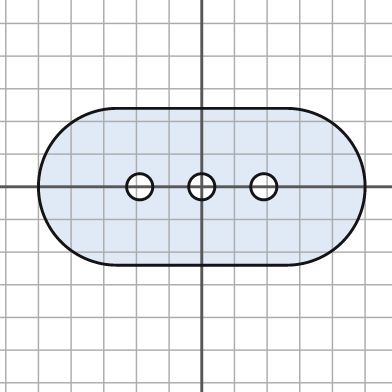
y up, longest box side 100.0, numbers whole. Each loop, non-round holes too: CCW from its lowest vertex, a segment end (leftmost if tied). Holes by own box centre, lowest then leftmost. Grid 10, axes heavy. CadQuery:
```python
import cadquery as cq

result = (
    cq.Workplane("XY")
    .moveTo(-26.0, -24.0)
    .lineTo(26.0, -24.0)
    .threePointArc((50.0, 0.0), (26.0, 24.0))
    .lineTo(-26.0, 24.0)
    .threePointArc((-50.0, 0.0), (-26.0, -24.0))
    .close()
    .moveTo(-19.0, 0.0)
    .circle(4.0)
    .moveTo(0.0, 0.0)
    .circle(4.0)
    .moveTo(19.0, 0.0)
    .circle(4.0)
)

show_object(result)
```